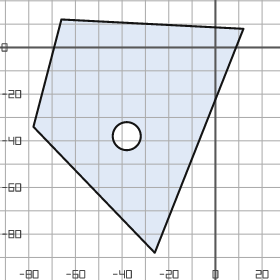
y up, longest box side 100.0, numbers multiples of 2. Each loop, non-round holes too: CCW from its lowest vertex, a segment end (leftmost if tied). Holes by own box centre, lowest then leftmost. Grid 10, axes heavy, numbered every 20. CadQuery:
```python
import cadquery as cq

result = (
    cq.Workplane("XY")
    .moveTo(-26.0, -88.0)
    .lineTo(12.0, 8.0)
    .lineTo(-66.0, 12.0)
    .lineTo(-78.0, -34.0)
    .close()
    .moveTo(-38.0, -38.0)
    .circle(6.0)
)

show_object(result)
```